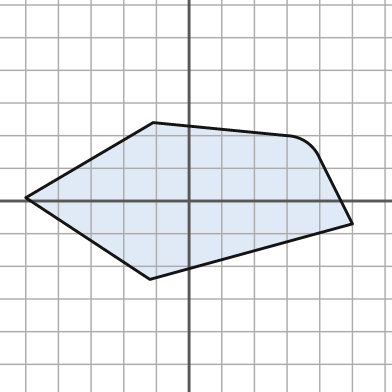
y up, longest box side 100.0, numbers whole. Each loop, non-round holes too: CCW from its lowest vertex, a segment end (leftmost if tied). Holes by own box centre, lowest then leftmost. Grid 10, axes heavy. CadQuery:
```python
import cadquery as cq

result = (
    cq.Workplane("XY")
    .moveTo(-12.0, -24.0)
    .lineTo(50.0, -7.0)
    .lineTo(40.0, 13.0)
    .threePointArc((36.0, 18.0), (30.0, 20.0))
    .lineTo(-11.0, 24.0)
    .lineTo(-50.0, 1.0)
    .close()
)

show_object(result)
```